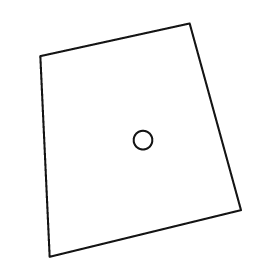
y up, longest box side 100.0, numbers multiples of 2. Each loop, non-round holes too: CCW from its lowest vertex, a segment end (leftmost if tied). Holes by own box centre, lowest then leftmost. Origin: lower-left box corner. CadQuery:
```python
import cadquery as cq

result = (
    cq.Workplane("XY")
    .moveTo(4.0, 0.0)
    .lineTo(86.0, 20.0)
    .lineTo(64.0, 100.0)
    .lineTo(0.0, 86.0)
    .close()
    .moveTo(44.0, 50.0)
    .circle(4.0)
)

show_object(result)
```